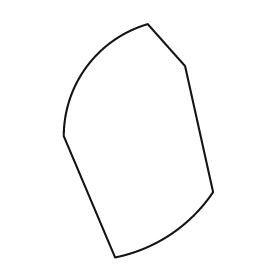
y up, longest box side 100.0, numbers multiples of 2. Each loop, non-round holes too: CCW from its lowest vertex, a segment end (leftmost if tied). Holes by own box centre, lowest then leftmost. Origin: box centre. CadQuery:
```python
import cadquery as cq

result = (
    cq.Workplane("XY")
    .moveTo(-10.0, -50.0)
    .threePointArc((14.0, -40.0), (32.0, -22.0))
    .lineTo(20.0, 32.0)
    .lineTo(4.0, 50.0)
    .threePointArc((-22.0, 32.0), (-32.0, 2.0))
    .close()
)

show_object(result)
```